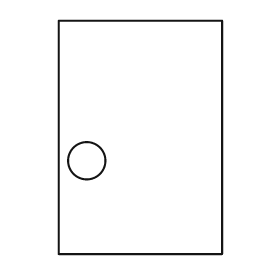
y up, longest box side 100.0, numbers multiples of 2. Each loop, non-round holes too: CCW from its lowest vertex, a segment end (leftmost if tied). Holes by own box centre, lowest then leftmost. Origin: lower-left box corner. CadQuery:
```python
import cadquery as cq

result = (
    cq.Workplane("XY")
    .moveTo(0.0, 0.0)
    .lineTo(70.0, 0.0)
    .lineTo(70.0, 100.0)
    .lineTo(0.0, 100.0)
    .close()
    .moveTo(12.0, 40.0)
    .circle(8.0)
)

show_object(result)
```